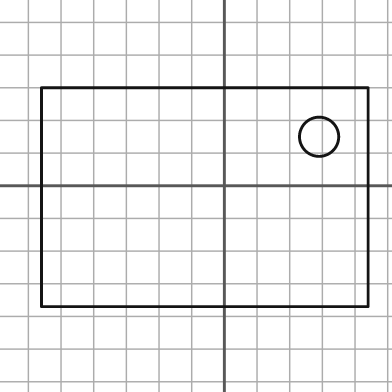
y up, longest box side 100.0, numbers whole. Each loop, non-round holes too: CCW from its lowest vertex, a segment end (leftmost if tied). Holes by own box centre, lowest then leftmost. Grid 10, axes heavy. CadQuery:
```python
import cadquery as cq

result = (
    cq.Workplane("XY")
    .moveTo(-56.0, -37.0)
    .lineTo(44.0, -37.0)
    .lineTo(44.0, 30.0)
    .lineTo(-56.0, 30.0)
    .close()
    .moveTo(29.0, 15.0)
    .circle(6.0)
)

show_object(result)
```